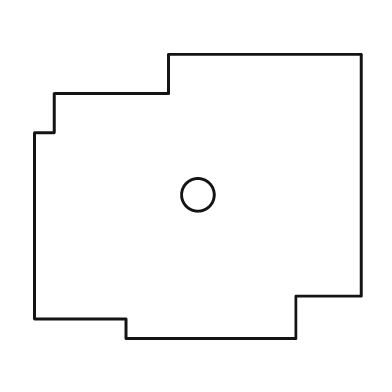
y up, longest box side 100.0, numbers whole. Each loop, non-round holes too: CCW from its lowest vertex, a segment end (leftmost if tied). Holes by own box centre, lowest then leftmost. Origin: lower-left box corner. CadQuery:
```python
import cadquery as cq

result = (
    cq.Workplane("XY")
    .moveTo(28.0, 0.0)
    .lineTo(80.0, 0.0)
    .lineTo(80.0, 13.0)
    .lineTo(100.0, 13.0)
    .lineTo(100.0, 87.0)
    .lineTo(41.0, 87.0)
    .lineTo(41.0, 75.0)
    .lineTo(6.0, 75.0)
    .lineTo(6.0, 63.0)
    .lineTo(0.0, 63.0)
    .lineTo(0.0, 6.0)
    .lineTo(28.0, 6.0)
    .close()
    .moveTo(50.0, 44.0)
    .circle(5.0)
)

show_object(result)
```